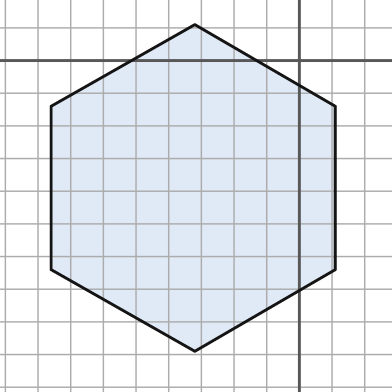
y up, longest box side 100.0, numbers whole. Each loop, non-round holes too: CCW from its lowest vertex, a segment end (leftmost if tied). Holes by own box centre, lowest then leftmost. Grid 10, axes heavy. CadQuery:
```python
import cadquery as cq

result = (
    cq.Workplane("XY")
    .moveTo(-32.0, -89.0)
    .lineTo(11.0, -64.0)
    .lineTo(11.0, -14.0)
    .lineTo(-32.0, 11.0)
    .lineTo(-76.0, -14.0)
    .lineTo(-76.0, -64.0)
    .close()
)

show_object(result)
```